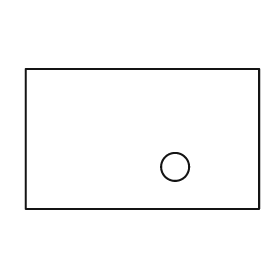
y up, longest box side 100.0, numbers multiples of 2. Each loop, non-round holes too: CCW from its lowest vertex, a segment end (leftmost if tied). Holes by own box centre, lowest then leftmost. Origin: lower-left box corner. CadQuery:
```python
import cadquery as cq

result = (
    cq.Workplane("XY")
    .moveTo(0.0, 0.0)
    .lineTo(100.0, 0.0)
    .lineTo(100.0, 60.0)
    .lineTo(0.0, 60.0)
    .close()
    .moveTo(64.0, 18.0)
    .circle(6.0)
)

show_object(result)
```